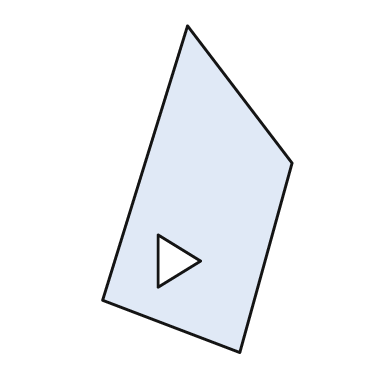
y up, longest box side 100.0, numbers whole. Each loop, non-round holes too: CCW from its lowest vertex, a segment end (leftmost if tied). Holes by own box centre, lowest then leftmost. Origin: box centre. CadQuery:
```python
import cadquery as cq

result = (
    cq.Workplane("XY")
    .moveTo(13.0, -50.0)
    .lineTo(29.0, 8.0)
    .lineTo(-3.0, 50.0)
    .lineTo(-29.0, -34.0)
    .close()
    .moveTo(-12.0, -30.0)
    .lineTo(1.0, -22.0)
    .lineTo(-12.0, -14.0)
    .close()
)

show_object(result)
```